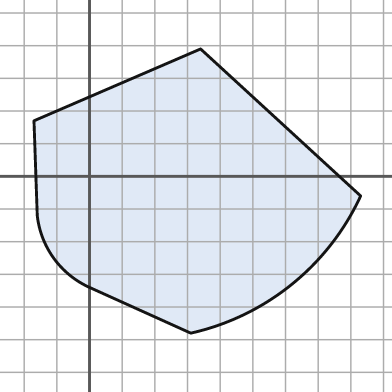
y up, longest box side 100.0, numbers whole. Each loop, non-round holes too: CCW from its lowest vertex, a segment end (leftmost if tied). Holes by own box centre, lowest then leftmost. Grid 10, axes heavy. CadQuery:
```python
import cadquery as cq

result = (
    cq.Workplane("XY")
    .moveTo(31.0, -48.0)
    .threePointArc((62.0, -33.0), (83.0, -6.0))
    .lineTo(34.0, 39.0)
    .lineTo(-17.0, 17.0)
    .lineTo(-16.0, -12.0)
    .threePointArc((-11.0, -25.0), (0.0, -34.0))
    .close()
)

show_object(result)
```